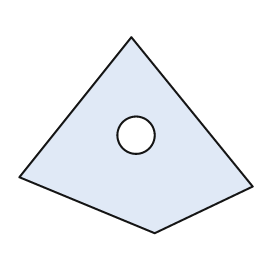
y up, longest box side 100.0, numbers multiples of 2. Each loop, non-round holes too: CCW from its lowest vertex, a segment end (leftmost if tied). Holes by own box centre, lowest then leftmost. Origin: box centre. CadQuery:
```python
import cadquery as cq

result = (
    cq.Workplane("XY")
    .moveTo(8.0, -42.0)
    .lineTo(50.0, -22.0)
    .lineTo(-2.0, 42.0)
    .lineTo(-50.0, -18.0)
    .close()
    .moveTo(0.0, 0.0)
    .circle(8.0)
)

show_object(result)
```